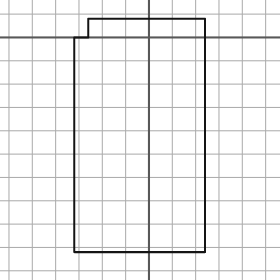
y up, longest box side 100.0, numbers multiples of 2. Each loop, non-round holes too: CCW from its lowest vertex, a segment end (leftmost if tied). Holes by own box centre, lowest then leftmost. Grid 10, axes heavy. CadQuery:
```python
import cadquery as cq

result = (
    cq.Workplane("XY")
    .moveTo(-32.0, -92.0)
    .lineTo(24.0, -92.0)
    .lineTo(24.0, 8.0)
    .lineTo(-26.0, 8.0)
    .lineTo(-26.0, 0.0)
    .lineTo(-32.0, 0.0)
    .close()
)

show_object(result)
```